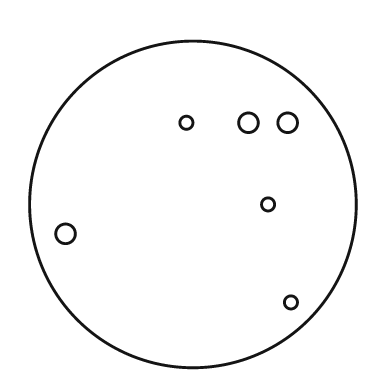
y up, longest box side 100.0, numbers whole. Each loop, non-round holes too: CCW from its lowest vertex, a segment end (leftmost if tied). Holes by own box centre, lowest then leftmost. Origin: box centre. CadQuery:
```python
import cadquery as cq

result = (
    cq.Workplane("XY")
    .moveTo(0.0, 0.0)
    .circle(50.0)
    .moveTo(30.0, -30.0)
    .circle(2.0)
    .moveTo(-39.0, -9.0)
    .circle(3.0)
    .moveTo(23.0, 0.0)
    .circle(2.0)
    .moveTo(-2.0, 25.0)
    .circle(2.0)
    .moveTo(17.0, 25.0)
    .circle(3.0)
    .moveTo(29.0, 25.0)
    .circle(3.0)
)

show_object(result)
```